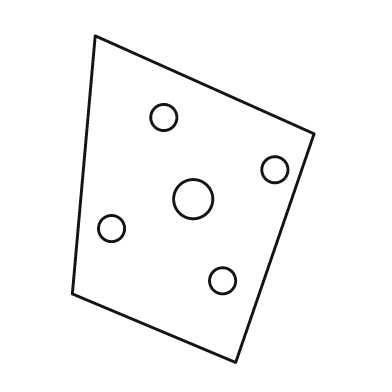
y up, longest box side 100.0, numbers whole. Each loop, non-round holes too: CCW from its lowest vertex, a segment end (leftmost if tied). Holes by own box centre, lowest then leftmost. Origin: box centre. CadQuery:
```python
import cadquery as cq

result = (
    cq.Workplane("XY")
    .moveTo(13.0, -50.0)
    .lineTo(37.0, 20.0)
    .lineTo(-30.0, 50.0)
    .lineTo(-37.0, -29.0)
    .close()
    .moveTo(9.0, -25.0)
    .circle(4.0)
    .moveTo(-25.0, -9.0)
    .circle(4.0)
    .moveTo(0.0, 0.0)
    .circle(6.0)
    .moveTo(25.0, 9.0)
    .circle(4.0)
    .moveTo(-9.0, 25.0)
    .circle(4.0)
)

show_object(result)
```